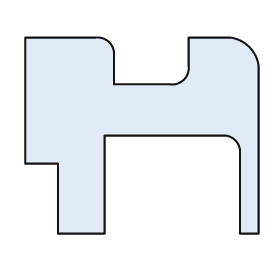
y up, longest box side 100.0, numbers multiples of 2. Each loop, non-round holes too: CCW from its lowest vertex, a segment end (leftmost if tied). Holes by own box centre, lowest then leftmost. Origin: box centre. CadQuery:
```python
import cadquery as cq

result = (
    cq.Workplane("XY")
    .moveTo(-36.0, -42.0)
    .lineTo(-16.0, -42.0)
    .lineTo(-16.0, 0.0)
    .lineTo(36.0, 0.0)
    .threePointArc((40.0, -2.0), (42.0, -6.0))
    .lineTo(42.0, -42.0)
    .lineTo(50.0, -42.0)
    .lineTo(50.0, 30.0)
    .threePointArc((46.0, 38.0), (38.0, 42.0))
    .lineTo(20.0, 42.0)
    .lineTo(20.0, 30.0)
    .threePointArc((18.0, 24.0), (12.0, 22.0))
    .lineTo(-12.0, 22.0)
    .lineTo(-12.0, 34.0)
    .threePointArc((-14.0, 40.0), (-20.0, 42.0))
    .lineTo(-50.0, 42.0)
    .lineTo(-50.0, -12.0)
    .lineTo(-36.0, -12.0)
    .close()
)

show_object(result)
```